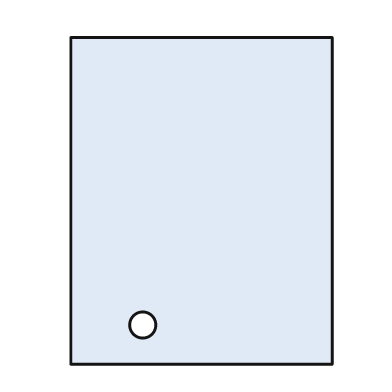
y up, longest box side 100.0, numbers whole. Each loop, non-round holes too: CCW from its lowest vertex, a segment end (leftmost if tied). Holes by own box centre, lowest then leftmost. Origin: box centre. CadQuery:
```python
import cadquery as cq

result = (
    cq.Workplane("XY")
    .moveTo(-40.0, -50.0)
    .lineTo(40.0, -50.0)
    .lineTo(40.0, 50.0)
    .lineTo(-40.0, 50.0)
    .close()
    .moveTo(-18.0, -38.0)
    .circle(4.0)
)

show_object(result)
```